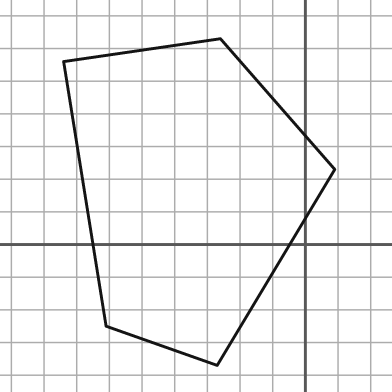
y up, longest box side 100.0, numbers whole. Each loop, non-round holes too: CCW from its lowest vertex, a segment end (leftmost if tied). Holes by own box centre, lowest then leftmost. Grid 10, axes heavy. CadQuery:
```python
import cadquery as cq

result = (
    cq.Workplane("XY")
    .moveTo(-27.0, -37.0)
    .lineTo(9.0, 23.0)
    .lineTo(-26.0, 63.0)
    .lineTo(-74.0, 56.0)
    .lineTo(-61.0, -25.0)
    .close()
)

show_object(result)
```